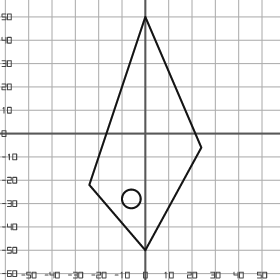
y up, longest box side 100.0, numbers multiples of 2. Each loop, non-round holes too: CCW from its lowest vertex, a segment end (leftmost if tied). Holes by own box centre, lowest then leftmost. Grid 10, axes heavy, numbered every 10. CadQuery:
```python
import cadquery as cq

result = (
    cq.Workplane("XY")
    .moveTo(0.0, -50.0)
    .lineTo(24.0, -6.0)
    .lineTo(0.0, 50.0)
    .lineTo(-24.0, -22.0)
    .close()
    .moveTo(-6.0, -28.0)
    .circle(4.0)
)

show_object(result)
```